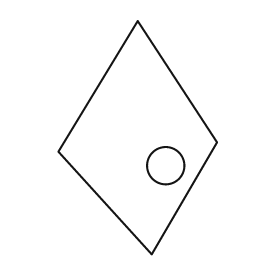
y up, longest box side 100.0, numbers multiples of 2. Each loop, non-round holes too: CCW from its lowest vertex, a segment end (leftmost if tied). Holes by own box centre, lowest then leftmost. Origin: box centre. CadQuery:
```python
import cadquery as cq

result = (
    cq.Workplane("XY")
    .moveTo(6.0, -50.0)
    .lineTo(34.0, -2.0)
    .lineTo(0.0, 50.0)
    .lineTo(-34.0, -6.0)
    .close()
    .moveTo(12.0, -12.0)
    .circle(8.0)
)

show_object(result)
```